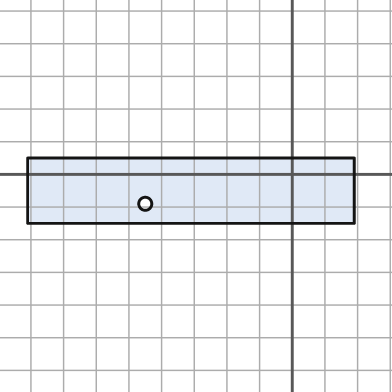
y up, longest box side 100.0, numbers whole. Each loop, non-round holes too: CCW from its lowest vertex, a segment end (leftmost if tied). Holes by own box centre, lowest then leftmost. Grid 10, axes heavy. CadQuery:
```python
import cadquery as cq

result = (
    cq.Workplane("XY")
    .moveTo(-81.0, -15.0)
    .lineTo(19.0, -15.0)
    .lineTo(19.0, 5.0)
    .lineTo(-81.0, 5.0)
    .close()
    .moveTo(-45.0, -9.0)
    .circle(2.0)
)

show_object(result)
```